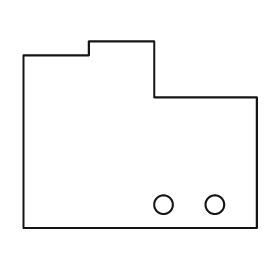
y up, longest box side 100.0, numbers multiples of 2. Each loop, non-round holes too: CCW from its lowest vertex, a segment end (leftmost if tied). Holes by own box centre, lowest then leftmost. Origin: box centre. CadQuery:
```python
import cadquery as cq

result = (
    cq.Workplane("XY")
    .moveTo(-50.0, -40.0)
    .lineTo(50.0, -40.0)
    .lineTo(50.0, 16.0)
    .lineTo(6.0, 16.0)
    .lineTo(6.0, 40.0)
    .lineTo(-22.0, 40.0)
    .lineTo(-22.0, 34.0)
    .lineTo(-50.0, 34.0)
    .close()
    .moveTo(10.0, -30.0)
    .circle(4.0)
    .moveTo(32.0, -30.0)
    .circle(4.0)
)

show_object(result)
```